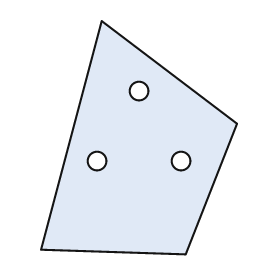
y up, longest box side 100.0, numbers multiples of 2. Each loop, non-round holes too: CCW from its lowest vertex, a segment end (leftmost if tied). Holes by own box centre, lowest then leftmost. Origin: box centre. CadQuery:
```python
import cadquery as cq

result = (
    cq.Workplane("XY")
    .moveTo(20.0, -50.0)
    .lineTo(42.0, 6.0)
    .lineTo(-16.0, 50.0)
    .lineTo(-42.0, -48.0)
    .close()
    .moveTo(-18.0, -10.0)
    .circle(4.0)
    .moveTo(18.0, -10.0)
    .circle(4.0)
    .moveTo(0.0, 20.0)
    .circle(4.0)
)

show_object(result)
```